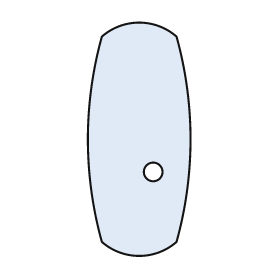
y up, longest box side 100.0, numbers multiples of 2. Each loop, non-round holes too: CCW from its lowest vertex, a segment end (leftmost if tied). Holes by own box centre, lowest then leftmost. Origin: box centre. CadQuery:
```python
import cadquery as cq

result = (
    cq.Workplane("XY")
    .moveTo(-16.0, -44.0)
    .threePointArc((0.0, -50.0), (16.0, -44.0))
    .threePointArc((22.0, 0.0), (16.0, 44.0))
    .threePointArc((0.0, 50.0), (-16.0, 44.0))
    .threePointArc((-22.0, 0.0), (-16.0, -44.0))
    .close()
    .moveTo(6.0, -14.0)
    .circle(4.0)
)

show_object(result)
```